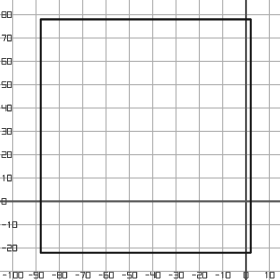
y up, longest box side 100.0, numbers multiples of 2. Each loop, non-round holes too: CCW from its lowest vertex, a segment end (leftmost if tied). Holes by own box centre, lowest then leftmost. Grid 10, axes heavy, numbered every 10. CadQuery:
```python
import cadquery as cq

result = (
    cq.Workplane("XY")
    .moveTo(-88.0, -22.0)
    .lineTo(2.0, -22.0)
    .lineTo(2.0, 78.0)
    .lineTo(-88.0, 78.0)
    .close()
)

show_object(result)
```